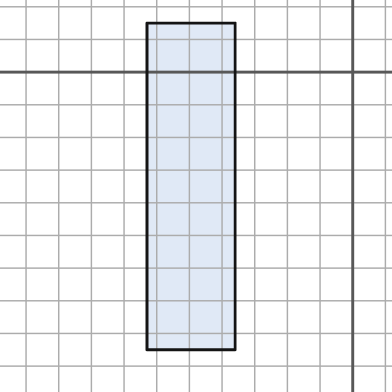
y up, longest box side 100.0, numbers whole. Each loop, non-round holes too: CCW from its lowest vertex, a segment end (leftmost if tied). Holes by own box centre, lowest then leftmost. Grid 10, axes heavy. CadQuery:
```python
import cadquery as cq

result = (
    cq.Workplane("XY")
    .moveTo(-63.0, -85.0)
    .lineTo(-36.0, -85.0)
    .lineTo(-36.0, 15.0)
    .lineTo(-63.0, 15.0)
    .close()
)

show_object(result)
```